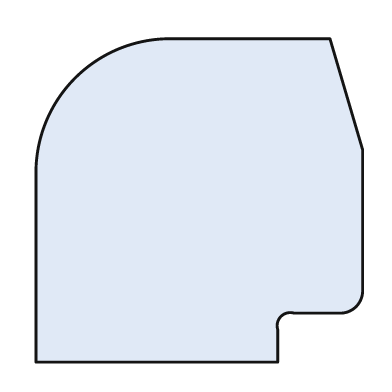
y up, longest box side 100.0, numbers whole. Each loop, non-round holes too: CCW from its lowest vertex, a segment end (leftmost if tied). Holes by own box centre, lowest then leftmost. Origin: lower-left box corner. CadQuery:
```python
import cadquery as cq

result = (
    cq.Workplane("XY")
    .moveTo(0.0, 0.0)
    .lineTo(74.0, 0.0)
    .lineTo(74.0, 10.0)
    .threePointArc((75.0, 14.0), (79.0, 15.0))
    .lineTo(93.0, 15.0)
    .threePointArc((98.0, 17.0), (100.0, 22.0))
    .lineTo(100.0, 65.0)
    .lineTo(90.0, 99.0)
    .lineTo(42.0, 99.0)
    .threePointArc((12.0, 87.0), (0.0, 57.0))
    .close()
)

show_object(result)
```